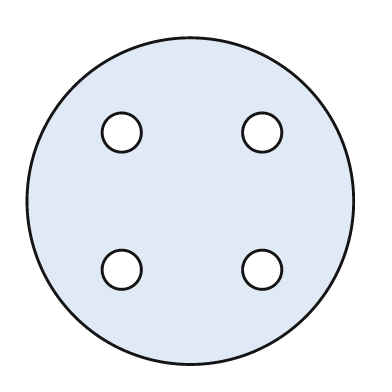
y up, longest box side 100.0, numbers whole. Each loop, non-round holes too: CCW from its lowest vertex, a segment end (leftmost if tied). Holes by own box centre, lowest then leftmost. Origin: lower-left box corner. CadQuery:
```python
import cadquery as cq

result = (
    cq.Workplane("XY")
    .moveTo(50.0, 50.0)
    .circle(50.0)
    .moveTo(29.0, 29.0)
    .circle(6.0)
    .moveTo(72.0, 29.0)
    .circle(6.0)
    .moveTo(29.0, 71.0)
    .circle(6.0)
    .moveTo(72.0, 71.0)
    .circle(6.0)
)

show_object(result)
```